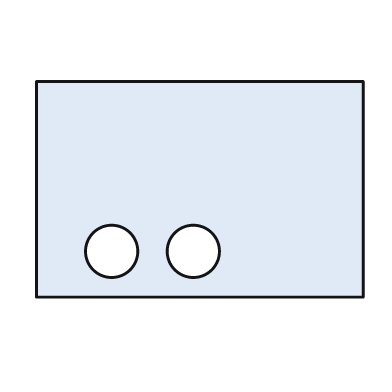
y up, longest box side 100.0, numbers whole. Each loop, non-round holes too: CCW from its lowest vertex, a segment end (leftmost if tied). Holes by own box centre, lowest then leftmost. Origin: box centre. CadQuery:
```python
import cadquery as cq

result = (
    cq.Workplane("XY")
    .moveTo(-50.0, -33.0)
    .lineTo(50.0, -33.0)
    .lineTo(50.0, 33.0)
    .lineTo(-50.0, 33.0)
    .close()
    .moveTo(-27.0, -19.0)
    .circle(8.0)
    .moveTo(-2.0, -19.0)
    .circle(8.0)
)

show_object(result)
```